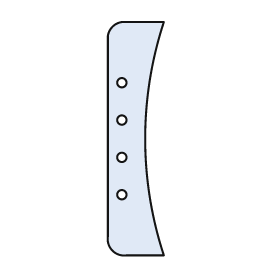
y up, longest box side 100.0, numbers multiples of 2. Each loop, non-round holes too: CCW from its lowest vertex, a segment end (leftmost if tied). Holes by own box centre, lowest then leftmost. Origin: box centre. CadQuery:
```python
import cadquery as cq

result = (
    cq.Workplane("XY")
    .moveTo(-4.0, -50.0)
    .lineTo(12.0, -50.0)
    .threePointArc((4.0, 0.0), (12.0, 50.0))
    .lineTo(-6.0, 50.0)
    .threePointArc((-10.0, 48.0), (-12.0, 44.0))
    .lineTo(-12.0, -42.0)
    .threePointArc((-10.0, -48.0), (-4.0, -50.0))
    .close()
    .moveTo(-6.0, -24.0)
    .circle(2.0)
    .moveTo(-6.0, -8.0)
    .circle(2.0)
    .moveTo(-6.0, 8.0)
    .circle(2.0)
    .moveTo(-6.0, 24.0)
    .circle(2.0)
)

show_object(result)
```